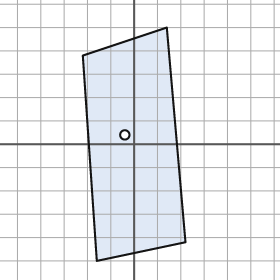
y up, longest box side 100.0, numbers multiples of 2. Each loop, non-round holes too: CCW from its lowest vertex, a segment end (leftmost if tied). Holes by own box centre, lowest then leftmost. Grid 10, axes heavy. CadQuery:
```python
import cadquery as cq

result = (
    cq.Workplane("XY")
    .moveTo(-16.0, -50.0)
    .lineTo(22.0, -42.0)
    .lineTo(14.0, 50.0)
    .lineTo(-22.0, 38.0)
    .close()
    .moveTo(-4.0, 4.0)
    .circle(2.0)
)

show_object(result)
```